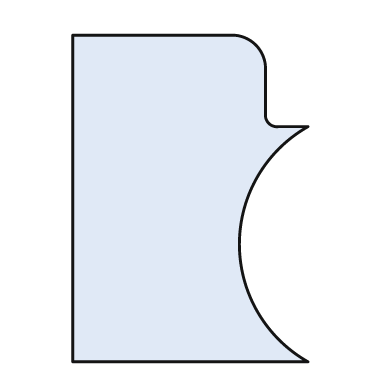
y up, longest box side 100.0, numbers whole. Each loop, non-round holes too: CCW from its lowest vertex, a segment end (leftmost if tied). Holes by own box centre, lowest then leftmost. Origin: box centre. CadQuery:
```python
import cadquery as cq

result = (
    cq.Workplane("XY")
    .moveTo(-36.0, -50.0)
    .lineTo(36.0, -50.0)
    .threePointArc((15.0, -14.0), (36.0, 22.0))
    .lineTo(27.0, 22.0)
    .threePointArc((24.0, 23.0), (23.0, 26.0))
    .lineTo(23.0, 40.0)
    .threePointArc((20.0, 47.0), (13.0, 50.0))
    .lineTo(-36.0, 50.0)
    .close()
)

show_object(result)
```